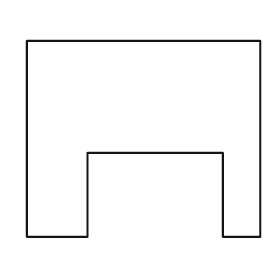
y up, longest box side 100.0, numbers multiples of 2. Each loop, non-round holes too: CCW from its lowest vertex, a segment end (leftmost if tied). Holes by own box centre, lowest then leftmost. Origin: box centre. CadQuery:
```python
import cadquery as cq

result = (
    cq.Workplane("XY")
    .moveTo(-50.0, -42.0)
    .lineTo(-24.0, -42.0)
    .lineTo(-24.0, -6.0)
    .lineTo(34.0, -6.0)
    .lineTo(34.0, -42.0)
    .lineTo(50.0, -42.0)
    .lineTo(50.0, 42.0)
    .lineTo(-50.0, 42.0)
    .close()
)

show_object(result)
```